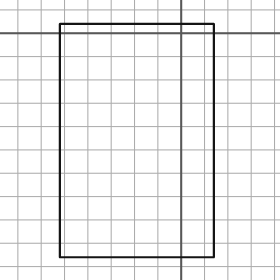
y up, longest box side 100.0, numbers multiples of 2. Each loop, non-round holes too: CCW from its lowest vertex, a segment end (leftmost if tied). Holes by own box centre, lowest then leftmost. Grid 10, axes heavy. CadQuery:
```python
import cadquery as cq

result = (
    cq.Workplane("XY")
    .moveTo(-52.0, -96.0)
    .lineTo(14.0, -96.0)
    .lineTo(14.0, 4.0)
    .lineTo(-52.0, 4.0)
    .close()
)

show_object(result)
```